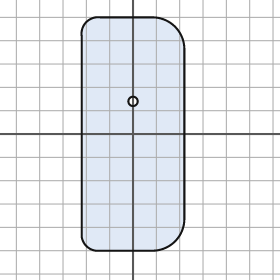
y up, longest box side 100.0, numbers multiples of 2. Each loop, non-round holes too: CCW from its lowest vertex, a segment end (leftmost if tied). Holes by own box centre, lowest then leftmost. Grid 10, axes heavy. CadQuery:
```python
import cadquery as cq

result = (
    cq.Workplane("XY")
    .moveTo(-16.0, -50.0)
    .lineTo(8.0, -50.0)
    .threePointArc((18.0, -46.0), (22.0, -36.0))
    .lineTo(22.0, 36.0)
    .threePointArc((18.0, 46.0), (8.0, 50.0))
    .lineTo(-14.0, 50.0)
    .threePointArc((-20.0, 48.0), (-22.0, 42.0))
    .lineTo(-22.0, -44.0)
    .threePointArc((-20.0, -48.0), (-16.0, -50.0))
    .close()
    .moveTo(0.0, 14.0)
    .circle(2.0)
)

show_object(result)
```